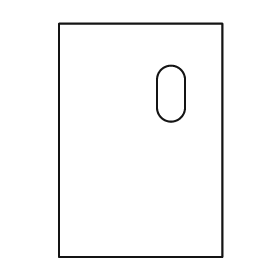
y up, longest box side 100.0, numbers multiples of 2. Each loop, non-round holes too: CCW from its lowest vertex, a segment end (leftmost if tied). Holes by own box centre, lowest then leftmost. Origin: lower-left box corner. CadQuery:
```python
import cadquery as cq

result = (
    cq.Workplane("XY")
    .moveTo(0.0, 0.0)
    .lineTo(70.0, 0.0)
    .lineTo(70.0, 100.0)
    .lineTo(0.0, 100.0)
    .close()
    .moveTo(42.0, 64.0)
    .threePointArc((48.0, 58.0), (54.0, 64.0))
    .lineTo(54.0, 76.0)
    .threePointArc((48.0, 82.0), (42.0, 76.0))
    .close()
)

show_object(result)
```